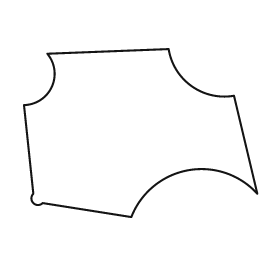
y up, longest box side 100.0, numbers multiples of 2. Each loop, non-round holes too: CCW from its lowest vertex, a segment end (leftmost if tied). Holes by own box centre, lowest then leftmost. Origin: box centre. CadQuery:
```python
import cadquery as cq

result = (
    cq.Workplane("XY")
    .moveTo(-4.0, -36.0)
    .threePointArc((20.0, -16.0), (50.0, -26.0))
    .lineTo(40.0, 16.0)
    .threePointArc((22.0, 20.0), (12.0, 36.0))
    .lineTo(-40.0, 34.0)
    .threePointArc((-38.0, 20.0), (-50.0, 12.0))
    .lineTo(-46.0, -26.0)
    .threePointArc((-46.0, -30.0), (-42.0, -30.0))
    .close()
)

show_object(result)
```